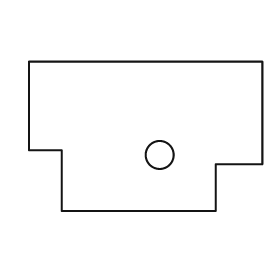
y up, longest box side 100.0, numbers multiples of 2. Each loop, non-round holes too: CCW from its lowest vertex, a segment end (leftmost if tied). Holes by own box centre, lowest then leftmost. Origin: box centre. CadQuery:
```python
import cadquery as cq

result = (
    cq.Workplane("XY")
    .moveTo(-36.0, -32.0)
    .lineTo(30.0, -32.0)
    .lineTo(30.0, -12.0)
    .lineTo(50.0, -12.0)
    .lineTo(50.0, 32.0)
    .lineTo(-50.0, 32.0)
    .lineTo(-50.0, -6.0)
    .lineTo(-36.0, -6.0)
    .close()
    .moveTo(6.0, -8.0)
    .circle(6.0)
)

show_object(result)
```